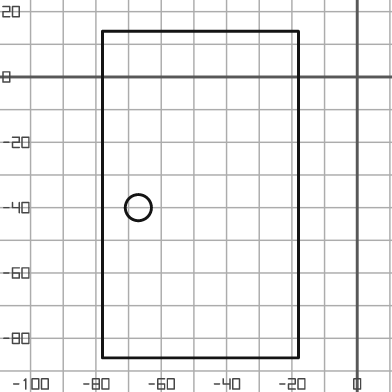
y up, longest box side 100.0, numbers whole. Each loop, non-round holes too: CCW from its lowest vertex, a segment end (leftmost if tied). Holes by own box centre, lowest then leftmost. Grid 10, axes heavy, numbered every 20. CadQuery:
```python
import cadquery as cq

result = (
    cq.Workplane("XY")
    .moveTo(-78.0, -86.0)
    .lineTo(-18.0, -86.0)
    .lineTo(-18.0, 14.0)
    .lineTo(-78.0, 14.0)
    .close()
    .moveTo(-67.0, -40.0)
    .circle(4.0)
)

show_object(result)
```